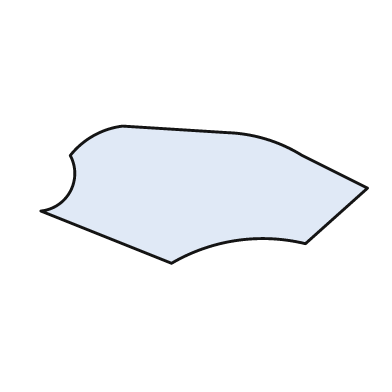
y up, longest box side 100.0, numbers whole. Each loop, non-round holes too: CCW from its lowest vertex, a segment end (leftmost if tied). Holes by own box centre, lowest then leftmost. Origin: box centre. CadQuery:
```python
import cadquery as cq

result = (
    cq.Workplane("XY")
    .moveTo(-10.0, -21.0)
    .threePointArc((10.0, -14.0), (31.0, -15.0))
    .lineTo(50.0, 2.0)
    .lineTo(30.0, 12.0)
    .threePointArc((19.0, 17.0), (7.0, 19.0))
    .lineTo(-25.0, 21.0)
    .threePointArc((-34.0, 18.0), (-41.0, 12.0))
    .threePointArc((-41.0, 1.0), (-50.0, -5.0))
    .close()
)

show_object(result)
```